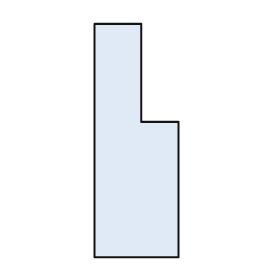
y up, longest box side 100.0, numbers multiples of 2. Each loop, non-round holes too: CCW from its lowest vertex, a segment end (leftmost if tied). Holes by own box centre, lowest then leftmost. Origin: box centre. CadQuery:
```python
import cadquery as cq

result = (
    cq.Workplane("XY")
    .moveTo(-18.0, -50.0)
    .lineTo(18.0, -50.0)
    .lineTo(18.0, 8.0)
    .lineTo(2.0, 8.0)
    .lineTo(2.0, 50.0)
    .lineTo(-18.0, 50.0)
    .close()
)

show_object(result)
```